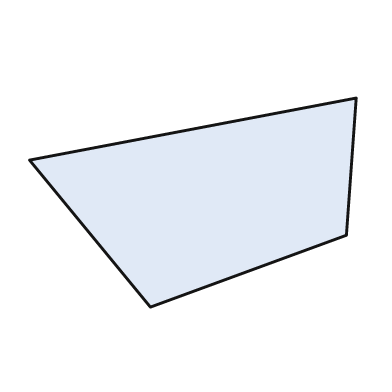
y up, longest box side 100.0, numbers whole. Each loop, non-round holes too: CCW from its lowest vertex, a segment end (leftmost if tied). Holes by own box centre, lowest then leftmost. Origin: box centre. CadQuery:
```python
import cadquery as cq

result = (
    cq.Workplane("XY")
    .moveTo(-13.0, -32.0)
    .lineTo(47.0, -10.0)
    .lineTo(50.0, 32.0)
    .lineTo(-50.0, 13.0)
    .close()
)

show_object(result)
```